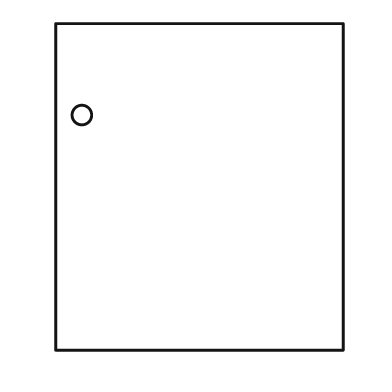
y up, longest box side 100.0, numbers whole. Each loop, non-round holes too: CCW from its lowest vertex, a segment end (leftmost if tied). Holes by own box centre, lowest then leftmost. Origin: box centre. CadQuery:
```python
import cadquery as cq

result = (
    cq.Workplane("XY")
    .moveTo(-44.0, -50.0)
    .lineTo(44.0, -50.0)
    .lineTo(44.0, 50.0)
    .lineTo(-44.0, 50.0)
    .close()
    .moveTo(-36.0, 22.0)
    .circle(3.0)
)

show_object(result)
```